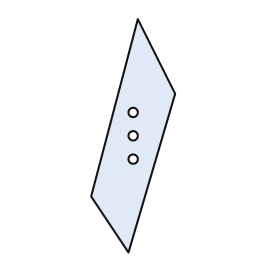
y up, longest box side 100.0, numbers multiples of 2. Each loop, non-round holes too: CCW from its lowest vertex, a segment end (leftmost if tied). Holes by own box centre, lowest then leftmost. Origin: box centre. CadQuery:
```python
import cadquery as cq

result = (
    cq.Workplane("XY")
    .moveTo(-2.0, -50.0)
    .lineTo(18.0, 18.0)
    .lineTo(2.0, 50.0)
    .lineTo(-18.0, -26.0)
    .close()
    .moveTo(0.0, -10.0)
    .circle(2.0)
    .moveTo(0.0, 0.0)
    .circle(2.0)
    .moveTo(0.0, 10.0)
    .circle(2.0)
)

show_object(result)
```